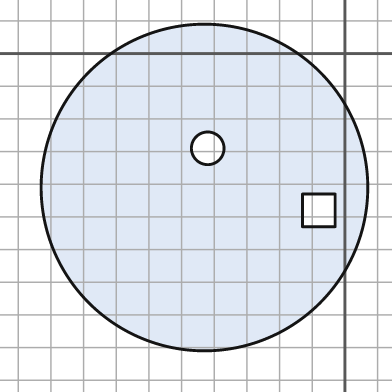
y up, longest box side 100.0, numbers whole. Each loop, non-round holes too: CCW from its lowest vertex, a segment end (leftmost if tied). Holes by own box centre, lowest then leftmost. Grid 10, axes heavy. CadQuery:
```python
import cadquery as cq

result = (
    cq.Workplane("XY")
    .moveTo(-43.0, -41.0)
    .circle(50.0)
    .moveTo(-13.0, -53.0)
    .lineTo(-3.0, -53.0)
    .lineTo(-3.0, -43.0)
    .lineTo(-13.0, -43.0)
    .close()
    .moveTo(-42.0, -29.0)
    .circle(5.0)
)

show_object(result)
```